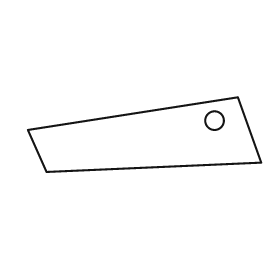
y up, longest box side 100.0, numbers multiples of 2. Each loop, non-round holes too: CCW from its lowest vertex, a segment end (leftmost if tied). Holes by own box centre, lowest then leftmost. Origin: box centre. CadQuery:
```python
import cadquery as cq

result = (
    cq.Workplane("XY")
    .moveTo(-42.0, -16.0)
    .lineTo(50.0, -12.0)
    .lineTo(40.0, 16.0)
    .lineTo(-50.0, 2.0)
    .close()
    .moveTo(30.0, 6.0)
    .circle(4.0)
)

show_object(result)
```